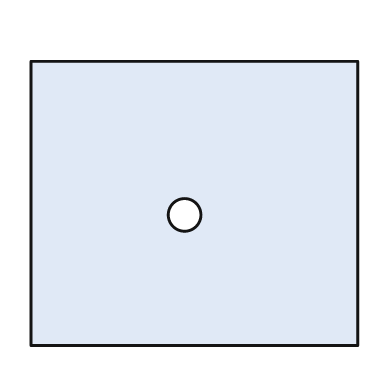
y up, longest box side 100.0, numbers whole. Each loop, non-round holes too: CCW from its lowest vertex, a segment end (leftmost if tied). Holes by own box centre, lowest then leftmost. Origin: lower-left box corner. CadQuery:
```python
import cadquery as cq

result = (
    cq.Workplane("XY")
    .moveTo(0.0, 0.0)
    .lineTo(100.0, 0.0)
    .lineTo(100.0, 87.0)
    .lineTo(0.0, 87.0)
    .close()
    .moveTo(47.0, 40.0)
    .circle(5.0)
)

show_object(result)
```